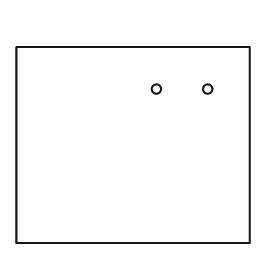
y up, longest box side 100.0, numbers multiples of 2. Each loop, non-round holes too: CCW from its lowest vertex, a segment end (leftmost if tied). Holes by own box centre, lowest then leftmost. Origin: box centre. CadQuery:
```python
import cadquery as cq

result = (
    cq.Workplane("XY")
    .moveTo(-50.0, -42.0)
    .lineTo(50.0, -42.0)
    .lineTo(50.0, 42.0)
    .lineTo(-50.0, 42.0)
    .close()
    .moveTo(10.0, 24.0)
    .circle(2.0)
    .moveTo(32.0, 24.0)
    .circle(2.0)
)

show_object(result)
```